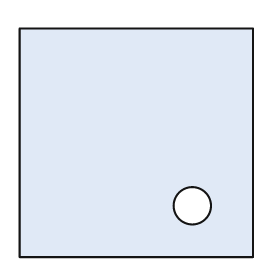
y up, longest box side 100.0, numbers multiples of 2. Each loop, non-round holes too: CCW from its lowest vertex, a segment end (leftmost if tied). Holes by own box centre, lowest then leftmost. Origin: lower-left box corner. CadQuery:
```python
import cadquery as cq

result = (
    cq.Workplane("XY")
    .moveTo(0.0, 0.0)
    .lineTo(100.0, 0.0)
    .lineTo(100.0, 98.0)
    .lineTo(0.0, 98.0)
    .close()
    .moveTo(74.0, 22.0)
    .circle(8.0)
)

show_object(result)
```